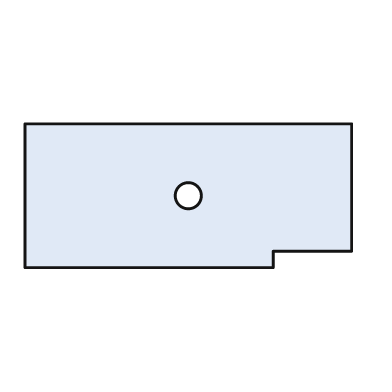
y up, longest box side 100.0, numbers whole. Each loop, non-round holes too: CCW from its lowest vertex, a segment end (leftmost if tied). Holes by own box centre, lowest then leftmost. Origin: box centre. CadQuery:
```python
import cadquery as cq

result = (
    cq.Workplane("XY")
    .moveTo(-50.0, -22.0)
    .lineTo(26.0, -22.0)
    .lineTo(26.0, -17.0)
    .lineTo(50.0, -17.0)
    .lineTo(50.0, 22.0)
    .lineTo(-50.0, 22.0)
    .close()
    .moveTo(0.0, 0.0)
    .circle(4.0)
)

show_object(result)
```